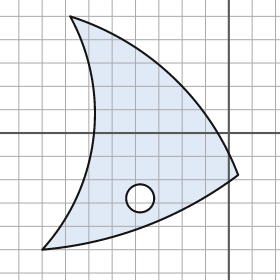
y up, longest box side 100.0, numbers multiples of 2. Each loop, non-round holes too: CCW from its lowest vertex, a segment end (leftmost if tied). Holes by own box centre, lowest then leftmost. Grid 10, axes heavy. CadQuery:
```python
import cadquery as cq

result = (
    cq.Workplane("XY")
    .moveTo(-80.0, -50.0)
    .threePointArc((-36.0, -40.0), (4.0, -18.0))
    .threePointArc((-24.0, 24.0), (-68.0, 50.0))
    .threePointArc((-58.0, -2.0), (-80.0, -50.0))
    .close()
    .moveTo(-38.0, -28.0)
    .circle(6.0)
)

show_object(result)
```